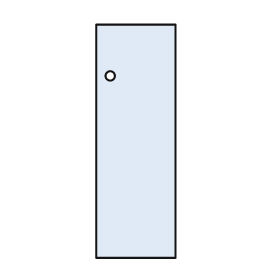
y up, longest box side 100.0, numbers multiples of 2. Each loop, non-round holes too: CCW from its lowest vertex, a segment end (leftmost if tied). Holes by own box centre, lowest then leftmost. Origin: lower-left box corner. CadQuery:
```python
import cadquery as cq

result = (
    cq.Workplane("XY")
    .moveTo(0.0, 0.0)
    .lineTo(34.0, 0.0)
    .lineTo(34.0, 100.0)
    .lineTo(0.0, 100.0)
    .close()
    .moveTo(6.0, 78.0)
    .circle(2.0)
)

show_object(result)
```